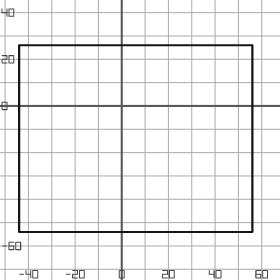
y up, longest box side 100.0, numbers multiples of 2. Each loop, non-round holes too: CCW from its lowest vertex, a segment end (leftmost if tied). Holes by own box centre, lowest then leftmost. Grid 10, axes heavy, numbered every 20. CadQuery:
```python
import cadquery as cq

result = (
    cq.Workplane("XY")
    .moveTo(-44.0, -54.0)
    .lineTo(56.0, -54.0)
    .lineTo(56.0, 26.0)
    .lineTo(-44.0, 26.0)
    .close()
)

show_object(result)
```